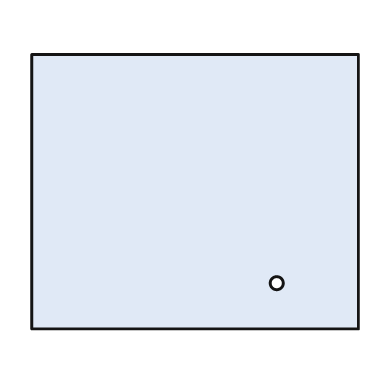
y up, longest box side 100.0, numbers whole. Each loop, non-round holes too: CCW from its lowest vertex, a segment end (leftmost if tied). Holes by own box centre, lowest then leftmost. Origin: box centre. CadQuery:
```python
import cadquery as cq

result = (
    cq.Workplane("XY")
    .moveTo(-50.0, -42.0)
    .lineTo(50.0, -42.0)
    .lineTo(50.0, 42.0)
    .lineTo(-50.0, 42.0)
    .close()
    .moveTo(25.0, -28.0)
    .circle(2.0)
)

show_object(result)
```